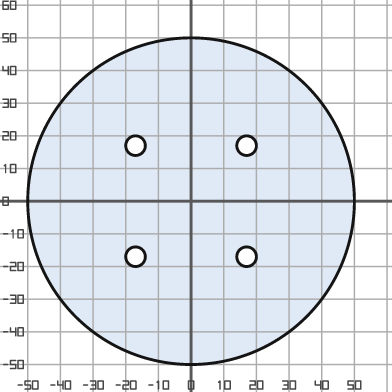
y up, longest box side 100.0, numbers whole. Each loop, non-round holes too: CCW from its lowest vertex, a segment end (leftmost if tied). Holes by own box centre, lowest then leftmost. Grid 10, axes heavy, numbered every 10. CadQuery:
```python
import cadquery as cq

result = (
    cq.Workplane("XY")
    .moveTo(0.0, 0.0)
    .circle(50.0)
    .moveTo(-17.0, -17.0)
    .circle(3.0)
    .moveTo(17.0, -17.0)
    .circle(3.0)
    .moveTo(-17.0, 17.0)
    .circle(3.0)
    .moveTo(17.0, 17.0)
    .circle(3.0)
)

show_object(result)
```